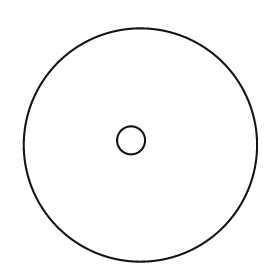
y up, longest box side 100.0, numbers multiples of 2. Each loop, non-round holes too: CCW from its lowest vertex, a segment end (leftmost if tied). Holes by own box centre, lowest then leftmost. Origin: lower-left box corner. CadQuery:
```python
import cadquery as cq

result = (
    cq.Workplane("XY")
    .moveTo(50.0, 50.0)
    .circle(50.0)
    .moveTo(46.0, 52.0)
    .circle(6.0)
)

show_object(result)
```